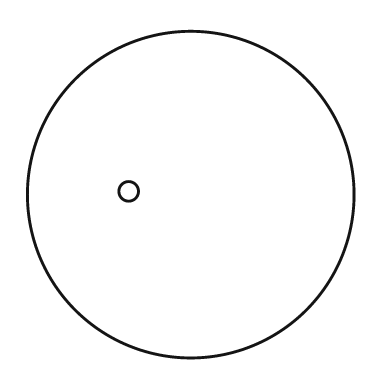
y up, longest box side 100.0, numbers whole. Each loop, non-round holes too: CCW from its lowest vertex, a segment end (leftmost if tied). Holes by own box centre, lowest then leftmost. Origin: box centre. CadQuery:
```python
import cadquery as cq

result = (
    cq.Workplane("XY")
    .moveTo(0.0, 0.0)
    .circle(50.0)
    .moveTo(-19.0, 1.0)
    .circle(3.0)
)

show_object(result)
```